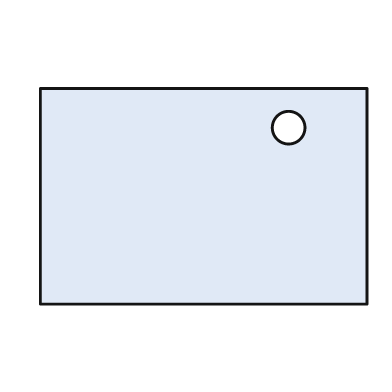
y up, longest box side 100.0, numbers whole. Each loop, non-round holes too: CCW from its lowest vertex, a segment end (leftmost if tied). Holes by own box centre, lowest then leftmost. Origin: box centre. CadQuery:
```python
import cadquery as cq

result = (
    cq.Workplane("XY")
    .moveTo(-50.0, -33.0)
    .lineTo(50.0, -33.0)
    .lineTo(50.0, 33.0)
    .lineTo(-50.0, 33.0)
    .close()
    .moveTo(26.0, 21.0)
    .circle(5.0)
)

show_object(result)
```